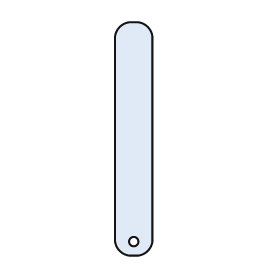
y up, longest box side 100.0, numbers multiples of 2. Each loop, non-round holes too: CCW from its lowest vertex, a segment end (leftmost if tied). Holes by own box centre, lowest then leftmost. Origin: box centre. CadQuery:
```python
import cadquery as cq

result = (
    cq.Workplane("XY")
    .moveTo(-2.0, -50.0)
    .lineTo(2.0, -50.0)
    .threePointArc((6.0, -48.0), (8.0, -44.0))
    .lineTo(8.0, 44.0)
    .threePointArc((6.0, 48.0), (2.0, 50.0))
    .lineTo(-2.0, 50.0)
    .threePointArc((-6.0, 48.0), (-8.0, 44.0))
    .lineTo(-8.0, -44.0)
    .threePointArc((-6.0, -48.0), (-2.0, -50.0))
    .close()
    .moveTo(0.0, -44.0)
    .circle(2.0)
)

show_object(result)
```